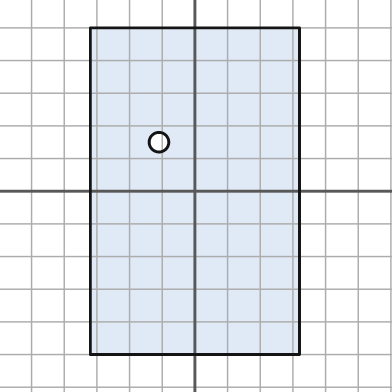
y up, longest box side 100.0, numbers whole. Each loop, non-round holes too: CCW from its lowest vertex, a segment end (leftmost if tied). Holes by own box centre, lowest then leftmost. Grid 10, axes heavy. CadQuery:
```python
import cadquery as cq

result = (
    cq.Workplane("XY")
    .moveTo(-32.0, -50.0)
    .lineTo(32.0, -50.0)
    .lineTo(32.0, 50.0)
    .lineTo(-32.0, 50.0)
    .close()
    .moveTo(-11.0, 15.0)
    .circle(3.0)
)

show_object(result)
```